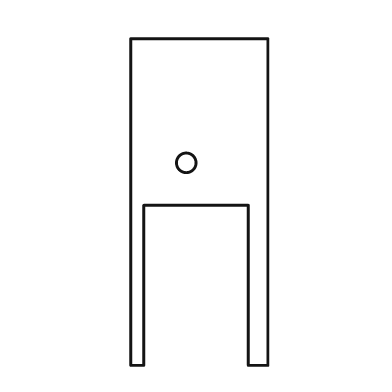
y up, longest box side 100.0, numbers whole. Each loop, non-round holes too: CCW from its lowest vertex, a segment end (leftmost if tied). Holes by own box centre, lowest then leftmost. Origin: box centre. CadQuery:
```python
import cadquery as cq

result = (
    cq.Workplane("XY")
    .moveTo(-21.0, -50.0)
    .lineTo(-17.0, -50.0)
    .lineTo(-17.0, -1.0)
    .lineTo(15.0, -1.0)
    .lineTo(15.0, -50.0)
    .lineTo(21.0, -50.0)
    .lineTo(21.0, 50.0)
    .lineTo(-21.0, 50.0)
    .close()
    .moveTo(-4.0, 12.0)
    .circle(3.0)
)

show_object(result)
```